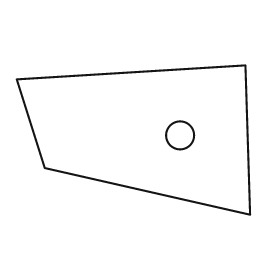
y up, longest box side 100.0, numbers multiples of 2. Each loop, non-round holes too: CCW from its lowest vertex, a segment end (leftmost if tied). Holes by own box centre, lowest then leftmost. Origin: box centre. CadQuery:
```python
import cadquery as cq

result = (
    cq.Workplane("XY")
    .moveTo(50.0, -32.0)
    .lineTo(48.0, 32.0)
    .lineTo(-50.0, 26.0)
    .lineTo(-38.0, -12.0)
    .close()
    .moveTo(20.0, 2.0)
    .circle(6.0)
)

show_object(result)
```